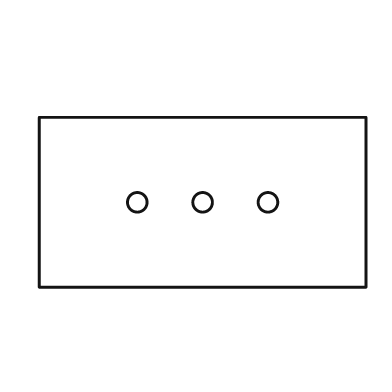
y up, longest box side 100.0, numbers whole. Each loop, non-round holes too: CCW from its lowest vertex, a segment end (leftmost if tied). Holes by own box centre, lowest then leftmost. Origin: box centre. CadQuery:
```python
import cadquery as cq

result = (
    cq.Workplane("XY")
    .moveTo(-50.0, -26.0)
    .lineTo(50.0, -26.0)
    .lineTo(50.0, 26.0)
    .lineTo(-50.0, 26.0)
    .close()
    .moveTo(-20.0, 0.0)
    .circle(3.0)
    .moveTo(0.0, 0.0)
    .circle(3.0)
    .moveTo(20.0, 0.0)
    .circle(3.0)
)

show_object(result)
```